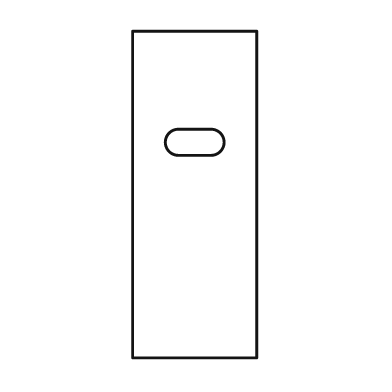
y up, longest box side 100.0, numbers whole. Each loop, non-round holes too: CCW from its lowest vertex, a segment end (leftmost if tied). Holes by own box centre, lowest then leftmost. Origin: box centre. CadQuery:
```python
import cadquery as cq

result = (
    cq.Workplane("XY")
    .moveTo(-19.0, -50.0)
    .lineTo(19.0, -50.0)
    .lineTo(19.0, 50.0)
    .lineTo(-19.0, 50.0)
    .close()
    .moveTo(-5.0, 12.0)
    .lineTo(5.0, 12.0)
    .threePointArc((9.0, 16.0), (5.0, 20.0))
    .lineTo(-5.0, 20.0)
    .threePointArc((-9.0, 16.0), (-5.0, 12.0))
    .close()
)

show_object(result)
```